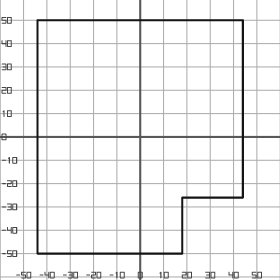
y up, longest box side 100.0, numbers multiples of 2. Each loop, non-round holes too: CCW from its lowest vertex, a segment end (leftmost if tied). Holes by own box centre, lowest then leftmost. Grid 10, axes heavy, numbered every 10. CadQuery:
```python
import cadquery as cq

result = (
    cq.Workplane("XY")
    .moveTo(-44.0, -50.0)
    .lineTo(18.0, -50.0)
    .lineTo(18.0, -26.0)
    .lineTo(44.0, -26.0)
    .lineTo(44.0, 50.0)
    .lineTo(-44.0, 50.0)
    .close()
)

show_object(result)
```